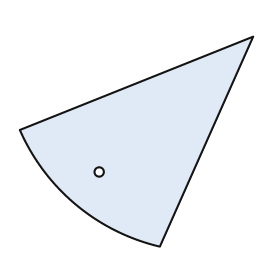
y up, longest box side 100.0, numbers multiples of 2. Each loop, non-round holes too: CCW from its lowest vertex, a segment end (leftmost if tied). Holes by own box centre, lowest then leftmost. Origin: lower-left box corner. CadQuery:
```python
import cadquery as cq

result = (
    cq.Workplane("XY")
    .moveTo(60.0, 0.0)
    .lineTo(100.0, 90.0)
    .lineTo(0.0, 50.0)
    .threePointArc((24.0, 18.0), (60.0, 0.0))
    .close()
    .moveTo(34.0, 32.0)
    .circle(2.0)
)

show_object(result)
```